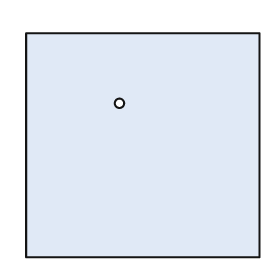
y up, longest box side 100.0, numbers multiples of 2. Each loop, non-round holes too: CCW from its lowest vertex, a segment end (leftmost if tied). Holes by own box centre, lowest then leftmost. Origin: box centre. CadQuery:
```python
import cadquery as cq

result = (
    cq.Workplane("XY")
    .moveTo(-50.0, -48.0)
    .lineTo(50.0, -48.0)
    .lineTo(50.0, 48.0)
    .lineTo(-50.0, 48.0)
    .close()
    .moveTo(-10.0, 18.0)
    .circle(2.0)
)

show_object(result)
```